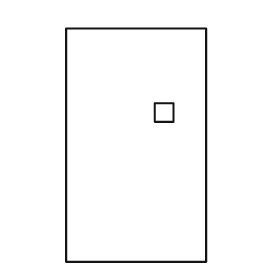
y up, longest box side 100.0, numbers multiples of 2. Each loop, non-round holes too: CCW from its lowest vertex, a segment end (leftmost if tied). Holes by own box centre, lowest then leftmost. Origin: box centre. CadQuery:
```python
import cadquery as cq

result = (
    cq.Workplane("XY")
    .moveTo(-30.0, -50.0)
    .lineTo(30.0, -50.0)
    .lineTo(30.0, 50.0)
    .lineTo(-30.0, 50.0)
    .close()
    .moveTo(8.0, 10.0)
    .lineTo(16.0, 10.0)
    .lineTo(16.0, 18.0)
    .lineTo(8.0, 18.0)
    .close()
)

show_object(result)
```